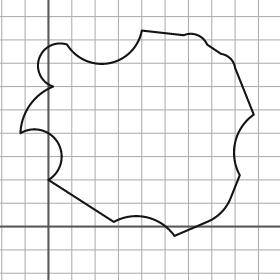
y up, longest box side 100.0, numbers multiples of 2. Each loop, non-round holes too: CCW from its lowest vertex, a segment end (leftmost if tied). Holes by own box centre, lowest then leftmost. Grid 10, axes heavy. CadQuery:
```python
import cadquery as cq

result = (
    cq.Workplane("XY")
    .moveTo(54.0, -4.0)
    .lineTo(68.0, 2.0)
    .threePointArc((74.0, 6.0), (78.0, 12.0))
    .lineTo(82.0, 22.0)
    .threePointArc((80.0, 36.0), (88.0, 48.0))
    .lineTo(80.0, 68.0)
    .threePointArc((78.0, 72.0), (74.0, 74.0))
    .lineTo(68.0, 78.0)
    .threePointArc((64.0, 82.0), (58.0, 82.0))
    .lineTo(40.0, 84.0)
    .threePointArc((26.0, 70.0), (8.0, 78.0))
    .threePointArc((-4.0, 72.0), (2.0, 60.0))
    .threePointArc((-8.0, 52.0), (-12.0, 40.0))
    .threePointArc((4.0, 36.0), (0.0, 20.0))
    .lineTo(28.0, 2.0)
    .threePointArc((42.0, 4.0), (54.0, -4.0))
    .close()
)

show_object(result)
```